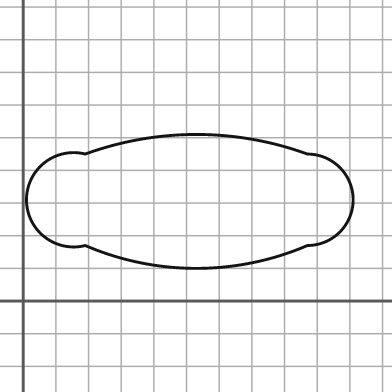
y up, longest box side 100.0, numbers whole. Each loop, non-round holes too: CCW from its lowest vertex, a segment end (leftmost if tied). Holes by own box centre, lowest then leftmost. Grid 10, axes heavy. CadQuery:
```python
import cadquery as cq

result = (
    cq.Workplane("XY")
    .moveTo(19.0, 17.0)
    .threePointArc((53.0, 10.0), (87.0, 17.0))
    .threePointArc((101.0, 31.0), (87.0, 45.0))
    .threePointArc((53.0, 51.0), (19.0, 45.0))
    .threePointArc((1.0, 31.0), (19.0, 17.0))
    .close()
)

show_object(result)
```